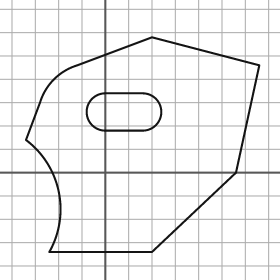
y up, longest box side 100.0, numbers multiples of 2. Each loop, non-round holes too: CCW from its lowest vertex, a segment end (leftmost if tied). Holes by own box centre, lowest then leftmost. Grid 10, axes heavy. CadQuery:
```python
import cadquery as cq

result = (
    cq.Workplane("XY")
    .moveTo(-24.0, -34.0)
    .lineTo(20.0, -34.0)
    .lineTo(56.0, 0.0)
    .lineTo(66.0, 46.0)
    .lineTo(20.0, 58.0)
    .lineTo(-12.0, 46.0)
    .threePointArc((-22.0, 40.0), (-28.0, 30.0))
    .lineTo(-34.0, 14.0)
    .threePointArc((-20.0, -8.0), (-24.0, -34.0))
    .close()
    .moveTo(0.0, 18.0)
    .lineTo(16.0, 18.0)
    .threePointArc((24.0, 26.0), (16.0, 34.0))
    .lineTo(0.0, 34.0)
    .threePointArc((-8.0, 26.0), (0.0, 18.0))
    .close()
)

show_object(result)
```